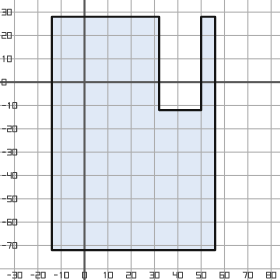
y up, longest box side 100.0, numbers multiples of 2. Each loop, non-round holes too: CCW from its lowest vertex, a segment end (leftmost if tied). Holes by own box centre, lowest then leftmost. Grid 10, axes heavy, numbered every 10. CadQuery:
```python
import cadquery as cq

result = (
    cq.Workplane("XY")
    .moveTo(-14.0, -72.0)
    .lineTo(56.0, -72.0)
    .lineTo(56.0, 28.0)
    .lineTo(50.0, 28.0)
    .lineTo(50.0, -12.0)
    .lineTo(32.0, -12.0)
    .lineTo(32.0, 28.0)
    .lineTo(-14.0, 28.0)
    .close()
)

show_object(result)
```